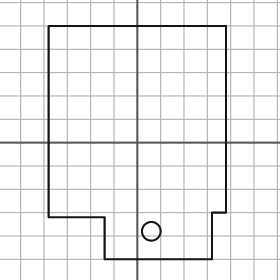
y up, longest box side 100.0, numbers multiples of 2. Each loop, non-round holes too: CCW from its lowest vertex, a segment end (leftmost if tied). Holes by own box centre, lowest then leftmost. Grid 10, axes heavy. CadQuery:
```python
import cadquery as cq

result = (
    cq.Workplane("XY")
    .moveTo(-14.0, -50.0)
    .lineTo(32.0, -50.0)
    .lineTo(32.0, -30.0)
    .lineTo(38.0, -30.0)
    .lineTo(38.0, 50.0)
    .lineTo(-38.0, 50.0)
    .lineTo(-38.0, -32.0)
    .lineTo(-14.0, -32.0)
    .close()
    .moveTo(6.0, -38.0)
    .circle(4.0)
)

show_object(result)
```